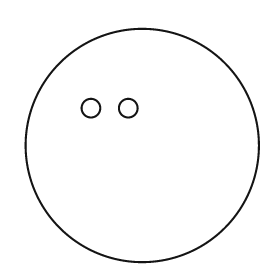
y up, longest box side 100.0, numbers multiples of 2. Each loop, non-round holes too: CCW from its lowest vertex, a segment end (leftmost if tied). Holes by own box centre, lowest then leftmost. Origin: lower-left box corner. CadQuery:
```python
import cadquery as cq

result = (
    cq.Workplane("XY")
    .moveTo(50.0, 50.0)
    .circle(50.0)
    .moveTo(28.0, 66.0)
    .circle(4.0)
    .moveTo(44.0, 66.0)
    .circle(4.0)
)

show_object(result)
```